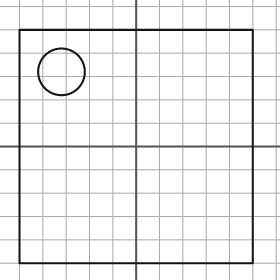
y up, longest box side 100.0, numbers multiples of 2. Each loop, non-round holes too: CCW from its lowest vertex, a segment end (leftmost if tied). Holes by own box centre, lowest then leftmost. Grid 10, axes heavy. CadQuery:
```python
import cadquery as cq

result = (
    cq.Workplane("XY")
    .moveTo(-50.0, -50.0)
    .lineTo(50.0, -50.0)
    .lineTo(50.0, 50.0)
    .lineTo(-50.0, 50.0)
    .close()
    .moveTo(-32.0, 32.0)
    .circle(10.0)
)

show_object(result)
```